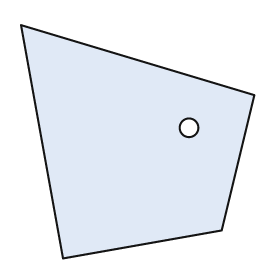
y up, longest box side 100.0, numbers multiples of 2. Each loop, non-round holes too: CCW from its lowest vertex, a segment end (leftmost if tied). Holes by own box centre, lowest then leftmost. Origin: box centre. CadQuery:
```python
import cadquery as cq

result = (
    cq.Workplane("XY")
    .moveTo(-32.0, -50.0)
    .lineTo(36.0, -38.0)
    .lineTo(50.0, 20.0)
    .lineTo(-50.0, 50.0)
    .close()
    .moveTo(22.0, 6.0)
    .circle(4.0)
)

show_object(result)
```